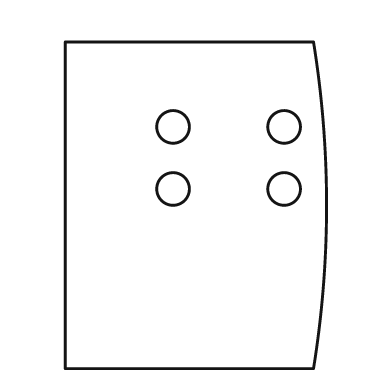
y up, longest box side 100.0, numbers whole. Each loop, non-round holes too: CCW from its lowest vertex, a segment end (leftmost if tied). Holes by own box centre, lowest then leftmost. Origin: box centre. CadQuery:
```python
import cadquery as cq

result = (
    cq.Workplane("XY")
    .moveTo(-40.0, -50.0)
    .lineTo(36.0, -50.0)
    .threePointArc((40.0, 0.0), (36.0, 50.0))
    .lineTo(-40.0, 50.0)
    .close()
    .moveTo(-7.0, 5.0)
    .circle(5.0)
    .moveTo(27.0, 5.0)
    .circle(5.0)
    .moveTo(-7.0, 24.0)
    .circle(5.0)
    .moveTo(27.0, 24.0)
    .circle(5.0)
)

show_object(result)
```